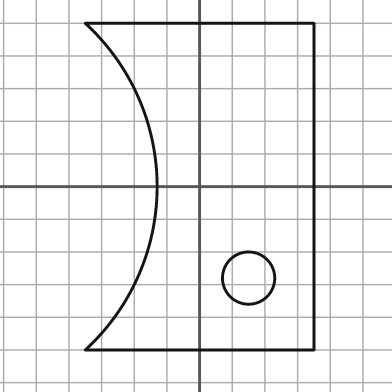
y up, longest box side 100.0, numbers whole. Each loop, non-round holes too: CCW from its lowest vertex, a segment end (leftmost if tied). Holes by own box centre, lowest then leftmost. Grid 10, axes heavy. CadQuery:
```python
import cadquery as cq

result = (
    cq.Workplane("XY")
    .moveTo(-35.0, -50.0)
    .lineTo(35.0, -50.0)
    .lineTo(35.0, 50.0)
    .lineTo(-35.0, 50.0)
    .threePointArc((-13.0, 0.0), (-35.0, -50.0))
    .close()
    .moveTo(15.0, -28.0)
    .circle(8.0)
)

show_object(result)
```